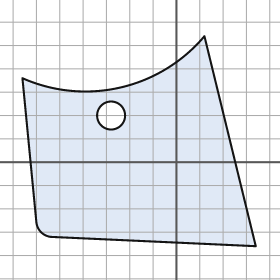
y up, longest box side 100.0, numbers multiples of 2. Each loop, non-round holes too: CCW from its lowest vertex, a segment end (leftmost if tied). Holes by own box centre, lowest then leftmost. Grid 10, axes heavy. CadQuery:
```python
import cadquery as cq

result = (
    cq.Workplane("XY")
    .moveTo(34.0, -36.0)
    .lineTo(12.0, 54.0)
    .threePointArc((-24.0, 32.0), (-66.0, 36.0))
    .lineTo(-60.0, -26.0)
    .threePointArc((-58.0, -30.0), (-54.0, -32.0))
    .close()
    .moveTo(-28.0, 20.0)
    .circle(6.0)
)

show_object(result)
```